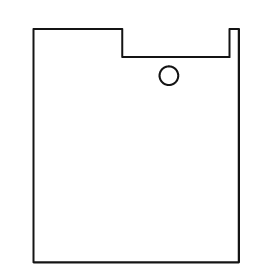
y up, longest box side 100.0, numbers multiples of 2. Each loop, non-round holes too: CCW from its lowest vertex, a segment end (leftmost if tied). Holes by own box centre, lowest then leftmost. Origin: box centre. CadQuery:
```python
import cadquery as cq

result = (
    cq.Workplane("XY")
    .moveTo(-44.0, -50.0)
    .lineTo(44.0, -50.0)
    .lineTo(44.0, 50.0)
    .lineTo(40.0, 50.0)
    .lineTo(40.0, 38.0)
    .lineTo(-6.0, 38.0)
    .lineTo(-6.0, 50.0)
    .lineTo(-44.0, 50.0)
    .close()
    .moveTo(14.0, 30.0)
    .circle(4.0)
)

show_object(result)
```